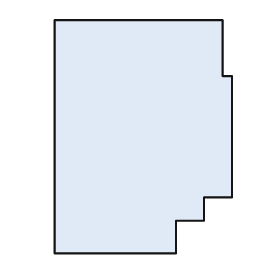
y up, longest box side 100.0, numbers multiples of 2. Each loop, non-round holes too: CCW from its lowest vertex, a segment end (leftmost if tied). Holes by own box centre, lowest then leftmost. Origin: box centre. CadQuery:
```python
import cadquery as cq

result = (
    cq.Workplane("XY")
    .moveTo(-38.0, -50.0)
    .lineTo(14.0, -50.0)
    .lineTo(14.0, -36.0)
    .lineTo(26.0, -36.0)
    .lineTo(26.0, -26.0)
    .lineTo(38.0, -26.0)
    .lineTo(38.0, 26.0)
    .lineTo(34.0, 26.0)
    .lineTo(34.0, 50.0)
    .lineTo(-38.0, 50.0)
    .close()
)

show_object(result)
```